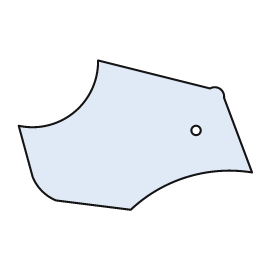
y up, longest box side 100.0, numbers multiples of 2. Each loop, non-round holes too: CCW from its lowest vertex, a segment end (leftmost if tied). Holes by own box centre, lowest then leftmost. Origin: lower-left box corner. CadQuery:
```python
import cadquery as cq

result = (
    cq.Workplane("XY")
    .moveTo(48.0, 0.0)
    .threePointArc((72.0, 14.0), (100.0, 16.0))
    .lineTo(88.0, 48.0)
    .threePointArc((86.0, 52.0), (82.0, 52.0))
    .lineTo(34.0, 64.0)
    .threePointArc((24.0, 42.0), (0.0, 36.0))
    .lineTo(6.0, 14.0)
    .threePointArc((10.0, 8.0), (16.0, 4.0))
    .close()
    .moveTo(76.0, 34.0)
    .circle(2.0)
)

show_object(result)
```